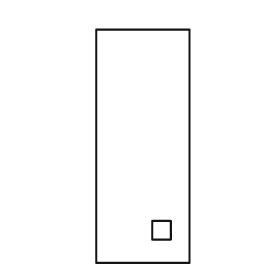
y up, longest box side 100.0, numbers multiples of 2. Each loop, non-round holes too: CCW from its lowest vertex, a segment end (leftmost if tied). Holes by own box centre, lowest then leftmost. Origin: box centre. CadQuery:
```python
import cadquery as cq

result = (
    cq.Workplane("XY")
    .moveTo(-20.0, -50.0)
    .lineTo(20.0, -50.0)
    .lineTo(20.0, 50.0)
    .lineTo(-20.0, 50.0)
    .close()
    .moveTo(4.0, -40.0)
    .lineTo(12.0, -40.0)
    .lineTo(12.0, -32.0)
    .lineTo(4.0, -32.0)
    .close()
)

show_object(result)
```